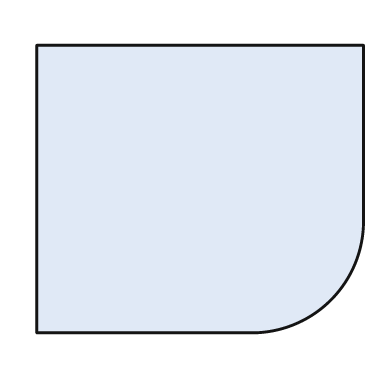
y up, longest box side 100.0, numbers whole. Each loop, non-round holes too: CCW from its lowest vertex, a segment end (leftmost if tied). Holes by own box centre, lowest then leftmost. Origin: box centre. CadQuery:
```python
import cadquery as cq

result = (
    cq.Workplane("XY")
    .moveTo(-50.0, -44.0)
    .lineTo(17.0, -44.0)
    .threePointArc((40.0, -34.0), (50.0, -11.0))
    .lineTo(50.0, 44.0)
    .lineTo(-50.0, 44.0)
    .close()
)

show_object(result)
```